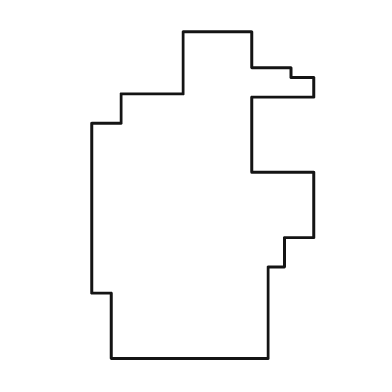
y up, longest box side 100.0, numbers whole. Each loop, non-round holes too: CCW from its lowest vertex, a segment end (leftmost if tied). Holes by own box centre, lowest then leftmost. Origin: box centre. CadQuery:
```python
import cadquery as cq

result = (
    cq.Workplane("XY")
    .moveTo(-28.0, -50.0)
    .lineTo(20.0, -50.0)
    .lineTo(20.0, -22.0)
    .lineTo(25.0, -22.0)
    .lineTo(25.0, -13.0)
    .lineTo(34.0, -13.0)
    .lineTo(34.0, 7.0)
    .lineTo(15.0, 7.0)
    .lineTo(15.0, 30.0)
    .lineTo(34.0, 30.0)
    .lineTo(34.0, 36.0)
    .lineTo(27.0, 36.0)
    .lineTo(27.0, 39.0)
    .lineTo(15.0, 39.0)
    .lineTo(15.0, 50.0)
    .lineTo(-6.0, 50.0)
    .lineTo(-6.0, 31.0)
    .lineTo(-25.0, 31.0)
    .lineTo(-25.0, 22.0)
    .lineTo(-34.0, 22.0)
    .lineTo(-34.0, -30.0)
    .lineTo(-28.0, -30.0)
    .close()
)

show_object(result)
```